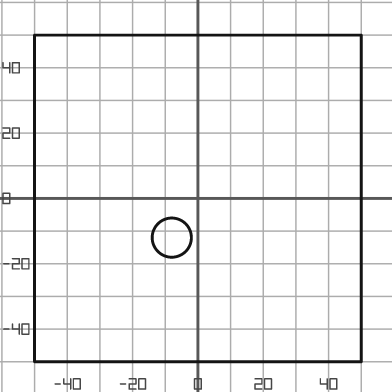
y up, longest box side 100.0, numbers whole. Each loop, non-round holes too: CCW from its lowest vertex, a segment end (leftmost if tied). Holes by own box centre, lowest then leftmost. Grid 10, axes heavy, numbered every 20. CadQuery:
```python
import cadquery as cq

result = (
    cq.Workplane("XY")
    .moveTo(-50.0, -50.0)
    .lineTo(50.0, -50.0)
    .lineTo(50.0, 50.0)
    .lineTo(-50.0, 50.0)
    .close()
    .moveTo(-8.0, -12.0)
    .circle(6.0)
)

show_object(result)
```